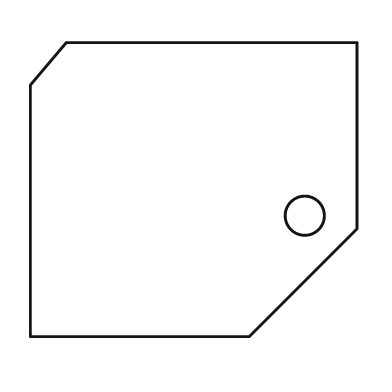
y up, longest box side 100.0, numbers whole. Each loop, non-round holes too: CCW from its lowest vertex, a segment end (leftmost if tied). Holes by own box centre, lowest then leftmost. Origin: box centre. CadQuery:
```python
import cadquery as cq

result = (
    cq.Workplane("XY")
    .moveTo(-50.0, -45.0)
    .lineTo(17.0, -45.0)
    .lineTo(50.0, -12.0)
    .lineTo(50.0, 45.0)
    .lineTo(-39.0, 45.0)
    .lineTo(-50.0, 32.0)
    .close()
    .moveTo(34.0, -8.0)
    .circle(6.0)
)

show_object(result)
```